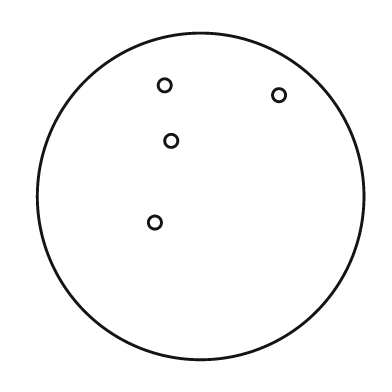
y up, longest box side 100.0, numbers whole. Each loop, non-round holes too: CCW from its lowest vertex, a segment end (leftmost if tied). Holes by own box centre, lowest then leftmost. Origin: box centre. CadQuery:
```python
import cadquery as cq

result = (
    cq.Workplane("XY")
    .moveTo(0.0, 0.0)
    .circle(50.0)
    .moveTo(-14.0, -8.0)
    .circle(2.0)
    .moveTo(-9.0, 17.0)
    .circle(2.0)
    .moveTo(24.0, 31.0)
    .circle(2.0)
    .moveTo(-11.0, 34.0)
    .circle(2.0)
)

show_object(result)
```